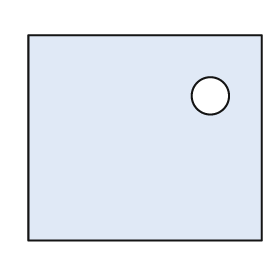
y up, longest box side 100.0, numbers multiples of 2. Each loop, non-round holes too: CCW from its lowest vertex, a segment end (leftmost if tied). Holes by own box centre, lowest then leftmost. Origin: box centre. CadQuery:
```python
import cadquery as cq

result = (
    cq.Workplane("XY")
    .moveTo(-50.0, -44.0)
    .lineTo(50.0, -44.0)
    .lineTo(50.0, 44.0)
    .lineTo(-50.0, 44.0)
    .close()
    .moveTo(28.0, 18.0)
    .circle(8.0)
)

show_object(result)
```